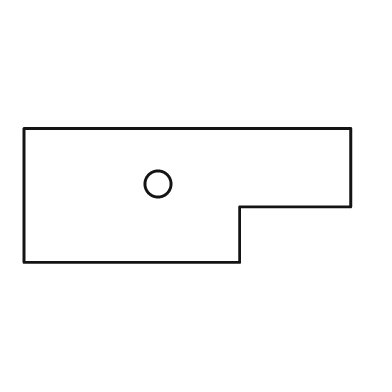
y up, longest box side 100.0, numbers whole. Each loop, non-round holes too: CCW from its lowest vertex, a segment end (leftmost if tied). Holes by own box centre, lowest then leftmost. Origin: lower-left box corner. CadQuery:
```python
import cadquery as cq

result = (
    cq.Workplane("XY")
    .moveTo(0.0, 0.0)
    .lineTo(66.0, 0.0)
    .lineTo(66.0, 17.0)
    .lineTo(100.0, 17.0)
    .lineTo(100.0, 41.0)
    .lineTo(0.0, 41.0)
    .close()
    .moveTo(41.0, 24.0)
    .circle(4.0)
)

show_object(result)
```